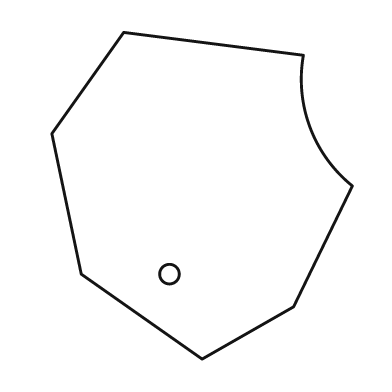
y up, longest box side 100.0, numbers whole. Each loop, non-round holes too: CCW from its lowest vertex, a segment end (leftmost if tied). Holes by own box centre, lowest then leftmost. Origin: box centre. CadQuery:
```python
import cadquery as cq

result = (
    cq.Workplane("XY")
    .moveTo(0.0, -50.0)
    .lineTo(28.0, -34.0)
    .lineTo(46.0, 3.0)
    .threePointArc((33.0, 21.0), (31.0, 43.0))
    .lineTo(-24.0, 50.0)
    .lineTo(-46.0, 19.0)
    .lineTo(-37.0, -24.0)
    .close()
    .moveTo(-10.0, -24.0)
    .circle(3.0)
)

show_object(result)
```